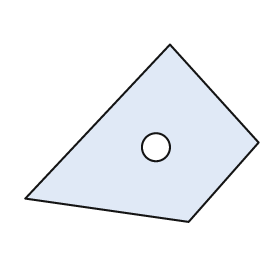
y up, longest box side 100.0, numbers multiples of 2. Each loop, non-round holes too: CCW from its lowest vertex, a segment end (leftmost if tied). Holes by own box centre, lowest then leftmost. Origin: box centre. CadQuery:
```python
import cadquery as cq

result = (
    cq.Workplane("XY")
    .moveTo(20.0, -38.0)
    .lineTo(50.0, -4.0)
    .lineTo(12.0, 38.0)
    .lineTo(-50.0, -28.0)
    .close()
    .moveTo(6.0, -6.0)
    .circle(6.0)
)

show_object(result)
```